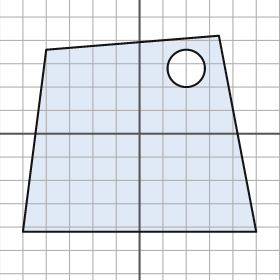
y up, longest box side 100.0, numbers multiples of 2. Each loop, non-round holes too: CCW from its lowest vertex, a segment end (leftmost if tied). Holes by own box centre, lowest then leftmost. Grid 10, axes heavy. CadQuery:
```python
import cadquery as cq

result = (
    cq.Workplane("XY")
    .moveTo(-50.0, -42.0)
    .lineTo(50.0, -42.0)
    .lineTo(34.0, 42.0)
    .lineTo(-40.0, 36.0)
    .close()
    .moveTo(20.0, 28.0)
    .circle(8.0)
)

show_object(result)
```